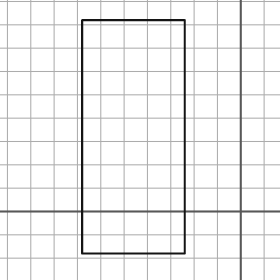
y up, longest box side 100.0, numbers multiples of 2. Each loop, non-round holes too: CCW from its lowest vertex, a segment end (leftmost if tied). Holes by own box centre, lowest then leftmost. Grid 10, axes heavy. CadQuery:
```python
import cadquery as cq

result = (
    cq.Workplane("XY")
    .moveTo(-68.0, -18.0)
    .lineTo(-24.0, -18.0)
    .lineTo(-24.0, 82.0)
    .lineTo(-68.0, 82.0)
    .close()
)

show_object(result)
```